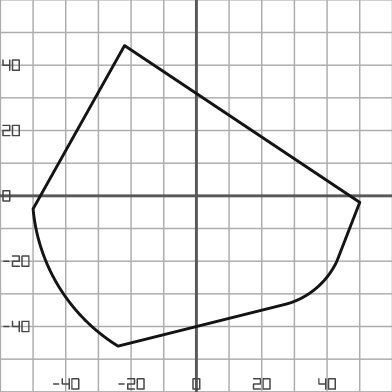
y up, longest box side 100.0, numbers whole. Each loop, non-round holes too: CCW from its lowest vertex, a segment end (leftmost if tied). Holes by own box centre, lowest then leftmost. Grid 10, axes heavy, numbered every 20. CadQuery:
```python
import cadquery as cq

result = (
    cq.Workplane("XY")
    .moveTo(-24.0, -46.0)
    .lineTo(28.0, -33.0)
    .threePointArc((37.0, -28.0), (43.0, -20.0))
    .lineTo(50.0, -2.0)
    .lineTo(-22.0, 46.0)
    .lineTo(-50.0, -4.0)
    .threePointArc((-42.0, -28.0), (-24.0, -46.0))
    .close()
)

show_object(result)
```